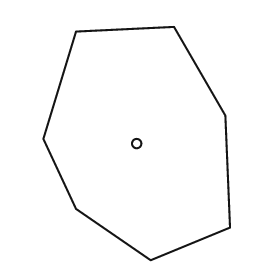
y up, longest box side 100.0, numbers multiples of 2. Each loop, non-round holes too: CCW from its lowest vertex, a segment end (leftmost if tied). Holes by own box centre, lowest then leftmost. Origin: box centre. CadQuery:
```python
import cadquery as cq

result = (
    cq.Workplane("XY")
    .moveTo(6.0, -50.0)
    .lineTo(40.0, -36.0)
    .lineTo(38.0, 12.0)
    .lineTo(16.0, 50.0)
    .lineTo(-26.0, 48.0)
    .lineTo(-40.0, 2.0)
    .lineTo(-26.0, -28.0)
    .close()
    .moveTo(0.0, 0.0)
    .circle(2.0)
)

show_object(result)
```